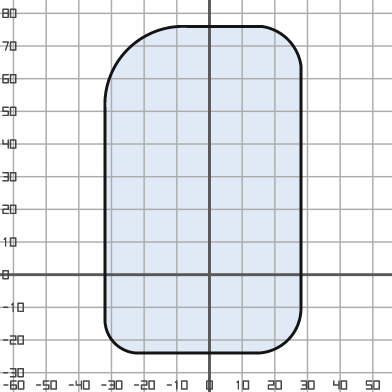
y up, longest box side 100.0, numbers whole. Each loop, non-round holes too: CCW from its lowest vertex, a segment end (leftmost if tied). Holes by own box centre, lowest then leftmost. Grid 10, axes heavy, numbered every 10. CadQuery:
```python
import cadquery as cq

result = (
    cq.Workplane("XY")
    .moveTo(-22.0, -24.0)
    .lineTo(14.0, -24.0)
    .threePointArc((24.0, -20.0), (28.0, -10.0))
    .lineTo(28.0, 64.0)
    .threePointArc((24.0, 72.0), (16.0, 76.0))
    .lineTo(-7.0, 76.0)
    .threePointArc((-25.0, 69.0), (-32.0, 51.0))
    .lineTo(-32.0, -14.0)
    .threePointArc((-29.0, -21.0), (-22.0, -24.0))
    .close()
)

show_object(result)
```